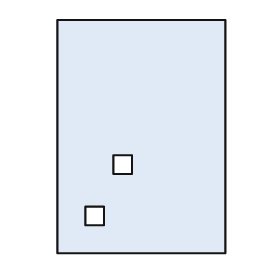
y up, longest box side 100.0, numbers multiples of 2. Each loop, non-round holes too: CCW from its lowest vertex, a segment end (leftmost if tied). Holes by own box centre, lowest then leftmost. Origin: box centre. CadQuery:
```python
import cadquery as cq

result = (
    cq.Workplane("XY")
    .moveTo(-36.0, -50.0)
    .lineTo(36.0, -50.0)
    .lineTo(36.0, 50.0)
    .lineTo(-36.0, 50.0)
    .close()
    .moveTo(-24.0, -38.0)
    .lineTo(-16.0, -38.0)
    .lineTo(-16.0, -30.0)
    .lineTo(-24.0, -30.0)
    .close()
    .moveTo(-12.0, -16.0)
    .lineTo(-4.0, -16.0)
    .lineTo(-4.0, -8.0)
    .lineTo(-12.0, -8.0)
    .close()
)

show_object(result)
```